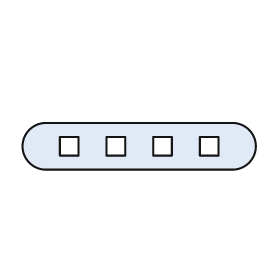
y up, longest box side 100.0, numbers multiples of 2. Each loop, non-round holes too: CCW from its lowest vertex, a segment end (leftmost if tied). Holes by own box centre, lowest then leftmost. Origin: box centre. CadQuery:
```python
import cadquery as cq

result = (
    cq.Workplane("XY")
    .moveTo(-40.0, -10.0)
    .lineTo(40.0, -10.0)
    .threePointArc((50.0, 0.0), (40.0, 10.0))
    .lineTo(-40.0, 10.0)
    .threePointArc((-50.0, 0.0), (-40.0, -10.0))
    .close()
    .moveTo(-34.0, -4.0)
    .lineTo(-26.0, -4.0)
    .lineTo(-26.0, 4.0)
    .lineTo(-34.0, 4.0)
    .close()
    .moveTo(-14.0, -4.0)
    .lineTo(-6.0, -4.0)
    .lineTo(-6.0, 4.0)
    .lineTo(-14.0, 4.0)
    .close()
    .moveTo(6.0, -4.0)
    .lineTo(14.0, -4.0)
    .lineTo(14.0, 4.0)
    .lineTo(6.0, 4.0)
    .close()
    .moveTo(26.0, -4.0)
    .lineTo(34.0, -4.0)
    .lineTo(34.0, 4.0)
    .lineTo(26.0, 4.0)
    .close()
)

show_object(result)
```